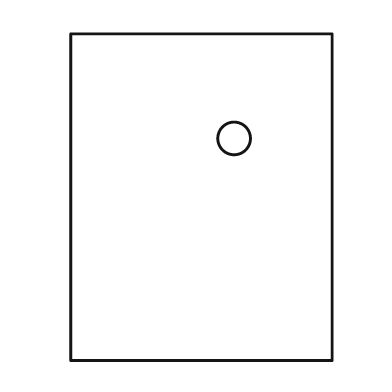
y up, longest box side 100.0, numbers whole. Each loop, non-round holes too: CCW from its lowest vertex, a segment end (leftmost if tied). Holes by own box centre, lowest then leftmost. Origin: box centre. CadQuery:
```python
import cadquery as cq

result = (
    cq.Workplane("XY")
    .moveTo(-40.0, -50.0)
    .lineTo(40.0, -50.0)
    .lineTo(40.0, 50.0)
    .lineTo(-40.0, 50.0)
    .close()
    .moveTo(10.0, 18.0)
    .circle(5.0)
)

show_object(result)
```